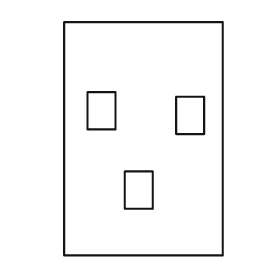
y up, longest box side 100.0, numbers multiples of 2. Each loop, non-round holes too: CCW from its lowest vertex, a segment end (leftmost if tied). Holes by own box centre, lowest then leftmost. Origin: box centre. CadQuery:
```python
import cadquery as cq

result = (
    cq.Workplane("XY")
    .moveTo(-34.0, -50.0)
    .lineTo(34.0, -50.0)
    .lineTo(34.0, 50.0)
    .lineTo(-34.0, 50.0)
    .close()
    .moveTo(-8.0, -30.0)
    .lineTo(4.0, -30.0)
    .lineTo(4.0, -14.0)
    .lineTo(-8.0, -14.0)
    .close()
    .moveTo(14.0, 2.0)
    .lineTo(26.0, 2.0)
    .lineTo(26.0, 18.0)
    .lineTo(14.0, 18.0)
    .close()
    .moveTo(-24.0, 4.0)
    .lineTo(-12.0, 4.0)
    .lineTo(-12.0, 20.0)
    .lineTo(-24.0, 20.0)
    .close()
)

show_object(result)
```